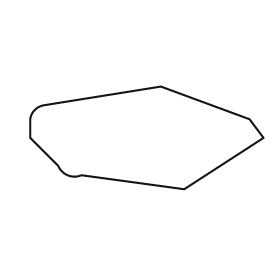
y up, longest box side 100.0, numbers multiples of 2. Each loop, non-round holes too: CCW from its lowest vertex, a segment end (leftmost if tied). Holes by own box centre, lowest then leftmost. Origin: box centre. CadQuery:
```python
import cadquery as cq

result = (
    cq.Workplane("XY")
    .moveTo(16.0, -22.0)
    .lineTo(50.0, 0.0)
    .lineTo(44.0, 8.0)
    .lineTo(6.0, 22.0)
    .lineTo(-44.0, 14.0)
    .threePointArc((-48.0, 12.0), (-50.0, 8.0))
    .lineTo(-50.0, 0.0)
    .lineTo(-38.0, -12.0)
    .threePointArc((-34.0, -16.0), (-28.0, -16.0))
    .close()
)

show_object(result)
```